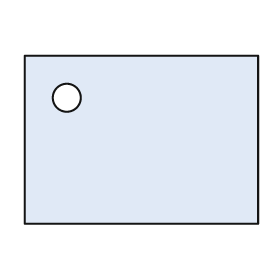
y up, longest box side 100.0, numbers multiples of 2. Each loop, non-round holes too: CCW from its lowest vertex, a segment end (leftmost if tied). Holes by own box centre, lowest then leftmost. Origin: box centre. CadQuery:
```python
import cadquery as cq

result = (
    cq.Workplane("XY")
    .moveTo(-50.0, -36.0)
    .lineTo(50.0, -36.0)
    .lineTo(50.0, 36.0)
    .lineTo(-50.0, 36.0)
    .close()
    .moveTo(-32.0, 18.0)
    .circle(6.0)
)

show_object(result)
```